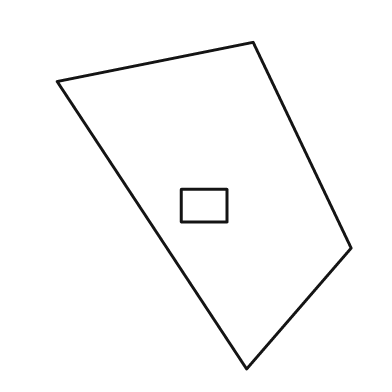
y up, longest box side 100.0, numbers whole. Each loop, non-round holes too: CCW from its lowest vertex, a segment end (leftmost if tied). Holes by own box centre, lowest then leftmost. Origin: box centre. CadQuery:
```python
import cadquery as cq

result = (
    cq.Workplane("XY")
    .moveTo(13.0, -50.0)
    .lineTo(45.0, -13.0)
    .lineTo(15.0, 50.0)
    .lineTo(-45.0, 38.0)
    .close()
    .moveTo(-7.0, -5.0)
    .lineTo(7.0, -5.0)
    .lineTo(7.0, 5.0)
    .lineTo(-7.0, 5.0)
    .close()
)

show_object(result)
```